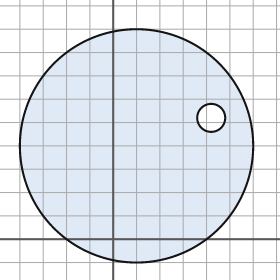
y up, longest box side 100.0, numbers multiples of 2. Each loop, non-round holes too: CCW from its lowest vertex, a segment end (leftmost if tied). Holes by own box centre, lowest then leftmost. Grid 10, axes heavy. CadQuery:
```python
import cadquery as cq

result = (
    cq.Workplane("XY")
    .moveTo(10.0, 40.0)
    .circle(50.0)
    .moveTo(42.0, 52.0)
    .circle(6.0)
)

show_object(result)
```